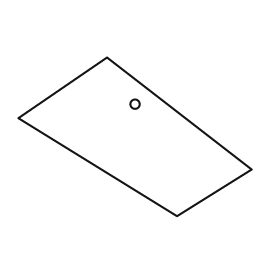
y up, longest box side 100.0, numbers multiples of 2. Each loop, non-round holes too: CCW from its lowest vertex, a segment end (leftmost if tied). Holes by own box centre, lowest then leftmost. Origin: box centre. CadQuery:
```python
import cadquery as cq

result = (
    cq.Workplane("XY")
    .moveTo(18.0, -34.0)
    .lineTo(50.0, -14.0)
    .lineTo(-12.0, 34.0)
    .lineTo(-50.0, 8.0)
    .close()
    .moveTo(0.0, 14.0)
    .circle(2.0)
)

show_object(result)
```